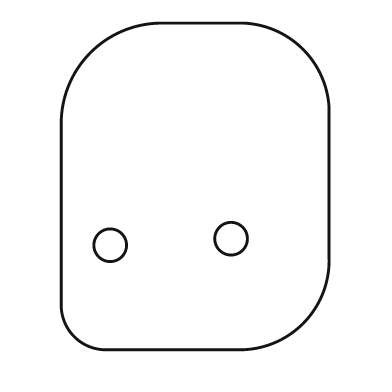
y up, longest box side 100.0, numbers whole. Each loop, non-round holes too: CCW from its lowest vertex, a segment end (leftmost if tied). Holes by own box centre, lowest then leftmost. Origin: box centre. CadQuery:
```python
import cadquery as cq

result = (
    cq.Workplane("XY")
    .moveTo(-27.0, -50.0)
    .lineTo(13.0, -50.0)
    .threePointArc((33.0, -42.0), (41.0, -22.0))
    .lineTo(41.0, 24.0)
    .threePointArc((33.0, 42.0), (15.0, 50.0))
    .lineTo(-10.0, 50.0)
    .threePointArc((-32.0, 41.0), (-41.0, 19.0))
    .lineTo(-41.0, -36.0)
    .threePointArc((-37.0, -46.0), (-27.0, -50.0))
    .close()
    .moveTo(-26.0, -18.0)
    .circle(5.0)
    .moveTo(11.0, -16.0)
    .circle(5.0)
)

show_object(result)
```